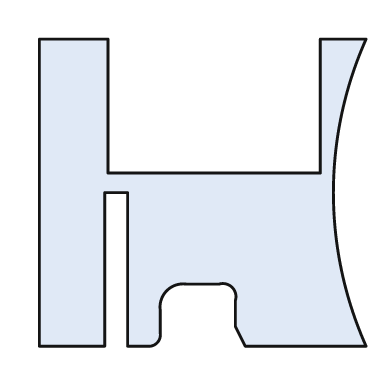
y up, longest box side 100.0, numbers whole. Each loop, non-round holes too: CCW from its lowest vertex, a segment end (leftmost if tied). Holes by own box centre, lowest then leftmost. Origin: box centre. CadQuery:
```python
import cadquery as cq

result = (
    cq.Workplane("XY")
    .moveTo(-50.0, -47.0)
    .lineTo(-30.0, -47.0)
    .lineTo(-30.0, 0.0)
    .lineTo(-23.0, 0.0)
    .lineTo(-23.0, -47.0)
    .lineTo(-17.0, -47.0)
    .threePointArc((-14.0, -46.0), (-13.0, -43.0))
    .lineTo(-13.0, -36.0)
    .threePointArc((-11.0, -30.0), (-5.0, -28.0))
    .lineTo(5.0, -28.0)
    .threePointArc((9.0, -29.0), (10.0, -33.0))
    .lineTo(10.0, -41.0)
    .lineTo(13.0, -47.0)
    .lineTo(50.0, -47.0)
    .threePointArc((40.0, 0.0), (50.0, 47.0))
    .lineTo(36.0, 47.0)
    .lineTo(36.0, 6.0)
    .lineTo(-29.0, 6.0)
    .lineTo(-29.0, 47.0)
    .lineTo(-50.0, 47.0)
    .close()
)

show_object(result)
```